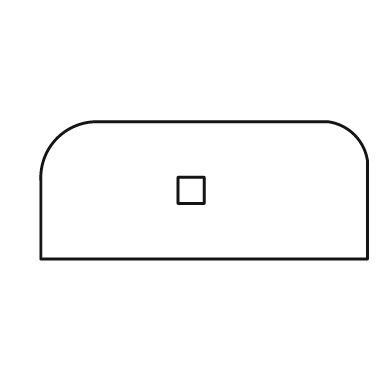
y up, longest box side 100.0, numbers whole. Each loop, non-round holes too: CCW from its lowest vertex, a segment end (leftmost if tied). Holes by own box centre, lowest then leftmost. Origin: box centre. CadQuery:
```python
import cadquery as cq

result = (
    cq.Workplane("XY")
    .moveTo(-50.0, -21.0)
    .lineTo(50.0, -21.0)
    .lineTo(50.0, 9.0)
    .threePointArc((46.0, 17.0), (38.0, 21.0))
    .lineTo(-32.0, 21.0)
    .threePointArc((-45.0, 16.0), (-50.0, 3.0))
    .close()
    .moveTo(-8.0, -4.0)
    .lineTo(0.0, -4.0)
    .lineTo(0.0, 4.0)
    .lineTo(-8.0, 4.0)
    .close()
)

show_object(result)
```